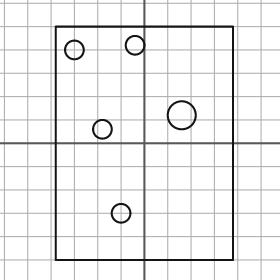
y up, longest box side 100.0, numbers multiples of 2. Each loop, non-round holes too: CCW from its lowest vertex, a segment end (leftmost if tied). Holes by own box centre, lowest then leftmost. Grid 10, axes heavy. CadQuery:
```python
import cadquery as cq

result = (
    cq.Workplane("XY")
    .moveTo(-38.0, -50.0)
    .lineTo(38.0, -50.0)
    .lineTo(38.0, 50.0)
    .lineTo(-38.0, 50.0)
    .close()
    .moveTo(-10.0, -30.0)
    .circle(4.0)
    .moveTo(-18.0, 6.0)
    .circle(4.0)
    .moveTo(16.0, 12.0)
    .circle(6.0)
    .moveTo(-30.0, 40.0)
    .circle(4.0)
    .moveTo(-4.0, 42.0)
    .circle(4.0)
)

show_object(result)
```